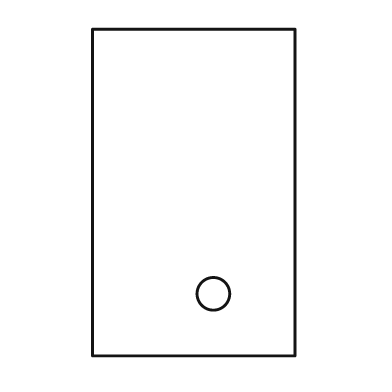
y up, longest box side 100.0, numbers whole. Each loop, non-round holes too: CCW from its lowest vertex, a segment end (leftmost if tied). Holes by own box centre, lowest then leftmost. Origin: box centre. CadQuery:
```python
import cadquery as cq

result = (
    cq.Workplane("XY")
    .moveTo(-31.0, -50.0)
    .lineTo(31.0, -50.0)
    .lineTo(31.0, 50.0)
    .lineTo(-31.0, 50.0)
    .close()
    .moveTo(6.0, -31.0)
    .circle(5.0)
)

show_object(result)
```